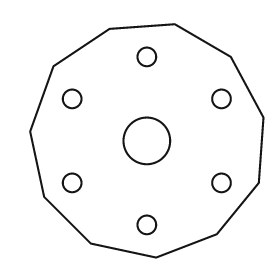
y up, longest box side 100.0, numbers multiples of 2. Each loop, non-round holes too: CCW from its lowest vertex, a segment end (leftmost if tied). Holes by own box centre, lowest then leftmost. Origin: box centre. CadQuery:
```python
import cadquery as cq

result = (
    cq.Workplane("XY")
    .moveTo(4.0, -50.0)
    .lineTo(30.0, -40.0)
    .lineTo(48.0, -18.0)
    .lineTo(50.0, 10.0)
    .lineTo(36.0, 36.0)
    .lineTo(12.0, 50.0)
    .lineTo(-16.0, 48.0)
    .lineTo(-40.0, 32.0)
    .lineTo(-50.0, 4.0)
    .lineTo(-44.0, -24.0)
    .lineTo(-24.0, -44.0)
    .close()
    .moveTo(0.0, -36.0)
    .circle(4.0)
    .moveTo(-32.0, -18.0)
    .circle(4.0)
    .moveTo(32.0, -18.0)
    .circle(4.0)
    .moveTo(0.0, 0.0)
    .circle(10.0)
    .moveTo(-32.0, 18.0)
    .circle(4.0)
    .moveTo(32.0, 18.0)
    .circle(4.0)
    .moveTo(0.0, 36.0)
    .circle(4.0)
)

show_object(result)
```